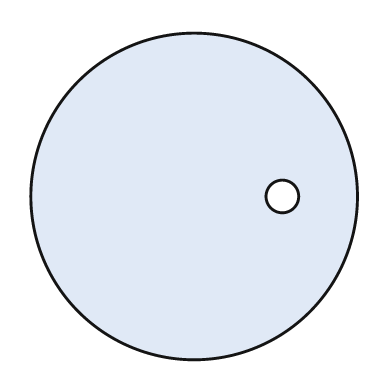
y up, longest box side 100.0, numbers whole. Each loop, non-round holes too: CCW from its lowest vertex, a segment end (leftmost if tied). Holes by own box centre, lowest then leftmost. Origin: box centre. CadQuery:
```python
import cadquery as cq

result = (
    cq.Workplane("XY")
    .moveTo(0.0, 0.0)
    .circle(50.0)
    .moveTo(27.0, 0.0)
    .circle(5.0)
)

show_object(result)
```